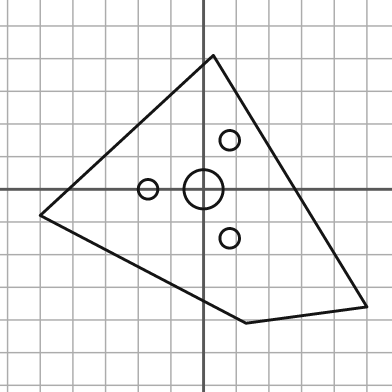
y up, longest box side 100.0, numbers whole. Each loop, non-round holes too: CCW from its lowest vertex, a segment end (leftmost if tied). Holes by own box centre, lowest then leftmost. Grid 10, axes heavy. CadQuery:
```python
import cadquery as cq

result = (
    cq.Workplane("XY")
    .moveTo(13.0, -41.0)
    .lineTo(50.0, -36.0)
    .lineTo(3.0, 41.0)
    .lineTo(-50.0, -8.0)
    .close()
    .moveTo(8.0, -15.0)
    .circle(3.0)
    .moveTo(-17.0, 0.0)
    .circle(3.0)
    .moveTo(0.0, 0.0)
    .circle(6.0)
    .moveTo(8.0, 15.0)
    .circle(3.0)
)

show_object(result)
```